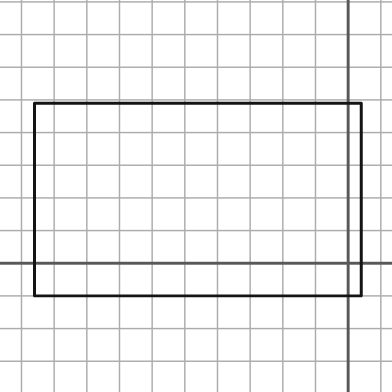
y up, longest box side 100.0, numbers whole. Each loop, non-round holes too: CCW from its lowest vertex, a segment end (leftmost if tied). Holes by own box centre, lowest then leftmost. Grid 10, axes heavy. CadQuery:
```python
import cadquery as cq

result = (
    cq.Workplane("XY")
    .moveTo(-96.0, -10.0)
    .lineTo(4.0, -10.0)
    .lineTo(4.0, 49.0)
    .lineTo(-96.0, 49.0)
    .close()
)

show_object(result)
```